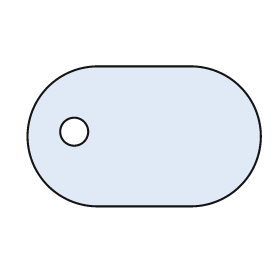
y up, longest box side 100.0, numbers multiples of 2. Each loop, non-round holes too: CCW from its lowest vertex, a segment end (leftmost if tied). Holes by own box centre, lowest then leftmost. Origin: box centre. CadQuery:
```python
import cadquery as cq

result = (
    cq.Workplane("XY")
    .moveTo(-20.0, -30.0)
    .lineTo(20.0, -30.0)
    .threePointArc((50.0, 0.0), (20.0, 30.0))
    .lineTo(-20.0, 30.0)
    .threePointArc((-50.0, 0.0), (-20.0, -30.0))
    .close()
    .moveTo(-30.0, 2.0)
    .circle(6.0)
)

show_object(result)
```